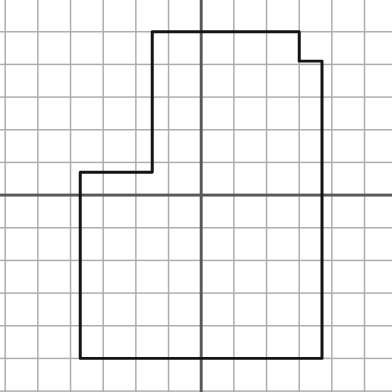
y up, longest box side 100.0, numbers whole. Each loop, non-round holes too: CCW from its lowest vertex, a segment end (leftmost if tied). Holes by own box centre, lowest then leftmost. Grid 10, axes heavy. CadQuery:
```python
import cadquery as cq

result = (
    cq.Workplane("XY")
    .moveTo(-37.0, -50.0)
    .lineTo(37.0, -50.0)
    .lineTo(37.0, 41.0)
    .lineTo(30.0, 41.0)
    .lineTo(30.0, 50.0)
    .lineTo(-15.0, 50.0)
    .lineTo(-15.0, 7.0)
    .lineTo(-37.0, 7.0)
    .close()
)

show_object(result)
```